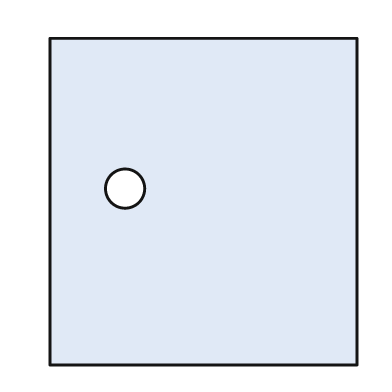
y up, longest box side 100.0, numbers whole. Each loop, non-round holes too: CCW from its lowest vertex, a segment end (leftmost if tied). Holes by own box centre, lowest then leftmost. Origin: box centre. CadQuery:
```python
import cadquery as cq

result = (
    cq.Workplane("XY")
    .moveTo(-47.0, -50.0)
    .lineTo(47.0, -50.0)
    .lineTo(47.0, 50.0)
    .lineTo(-47.0, 50.0)
    .close()
    .moveTo(-24.0, 4.0)
    .circle(6.0)
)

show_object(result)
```